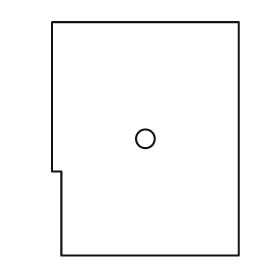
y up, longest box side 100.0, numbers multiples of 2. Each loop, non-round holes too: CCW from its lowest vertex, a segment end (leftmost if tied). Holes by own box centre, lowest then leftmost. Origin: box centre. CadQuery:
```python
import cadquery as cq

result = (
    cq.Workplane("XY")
    .moveTo(-36.0, -50.0)
    .lineTo(40.0, -50.0)
    .lineTo(40.0, 50.0)
    .lineTo(-40.0, 50.0)
    .lineTo(-40.0, -14.0)
    .lineTo(-36.0, -14.0)
    .close()
    .moveTo(0.0, 0.0)
    .circle(4.0)
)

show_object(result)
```